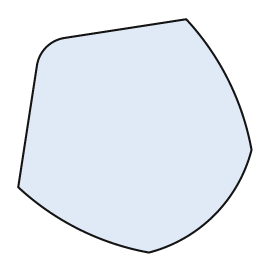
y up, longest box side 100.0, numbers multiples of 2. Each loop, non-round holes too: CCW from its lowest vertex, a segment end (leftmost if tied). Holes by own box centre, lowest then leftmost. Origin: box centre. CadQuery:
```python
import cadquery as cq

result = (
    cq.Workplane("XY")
    .moveTo(6.0, -50.0)
    .threePointArc((34.0, -34.0), (50.0, -6.0))
    .threePointArc((40.0, 24.0), (22.0, 50.0))
    .lineTo(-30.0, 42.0)
    .threePointArc((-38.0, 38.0), (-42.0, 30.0))
    .lineTo(-50.0, -22.0)
    .threePointArc((-24.0, -40.0), (6.0, -50.0))
    .close()
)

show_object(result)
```